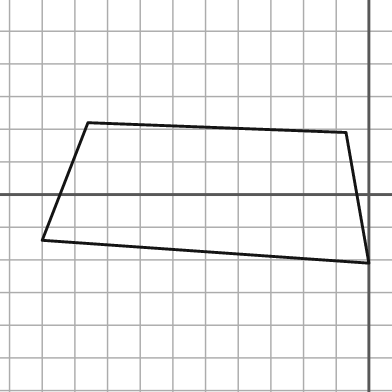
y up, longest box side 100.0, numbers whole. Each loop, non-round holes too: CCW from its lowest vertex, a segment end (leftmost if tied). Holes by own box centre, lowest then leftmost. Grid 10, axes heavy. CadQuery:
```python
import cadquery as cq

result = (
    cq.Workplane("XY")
    .moveTo(0.0, -21.0)
    .lineTo(-7.0, 19.0)
    .lineTo(-86.0, 22.0)
    .lineTo(-100.0, -14.0)
    .close()
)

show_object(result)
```